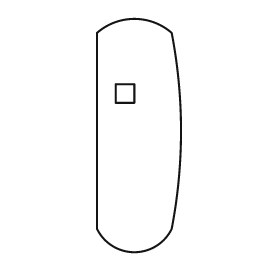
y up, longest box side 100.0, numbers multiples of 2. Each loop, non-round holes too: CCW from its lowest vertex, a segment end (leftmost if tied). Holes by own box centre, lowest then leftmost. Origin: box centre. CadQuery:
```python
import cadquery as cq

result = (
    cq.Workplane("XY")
    .moveTo(-18.0, -40.0)
    .threePointArc((-2.0, -50.0), (14.0, -40.0))
    .threePointArc((18.0, 2.0), (14.0, 44.0))
    .threePointArc((-2.0, 50.0), (-18.0, 44.0))
    .close()
    .moveTo(-10.0, 14.0)
    .lineTo(-2.0, 14.0)
    .lineTo(-2.0, 22.0)
    .lineTo(-10.0, 22.0)
    .close()
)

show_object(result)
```